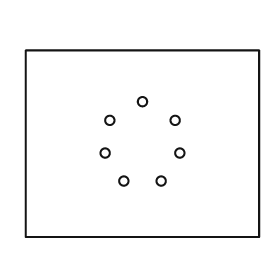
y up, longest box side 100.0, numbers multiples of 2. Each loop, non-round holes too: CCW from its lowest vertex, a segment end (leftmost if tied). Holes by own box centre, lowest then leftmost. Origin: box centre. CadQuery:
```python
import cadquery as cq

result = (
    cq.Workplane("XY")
    .moveTo(-50.0, -40.0)
    .lineTo(50.0, -40.0)
    .lineTo(50.0, 40.0)
    .lineTo(-50.0, 40.0)
    .close()
    .moveTo(-8.0, -16.0)
    .circle(2.0)
    .moveTo(8.0, -16.0)
    .circle(2.0)
    .moveTo(-16.0, -4.0)
    .circle(2.0)
    .moveTo(16.0, -4.0)
    .circle(2.0)
    .moveTo(-14.0, 10.0)
    .circle(2.0)
    .moveTo(14.0, 10.0)
    .circle(2.0)
    .moveTo(0.0, 18.0)
    .circle(2.0)
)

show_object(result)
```